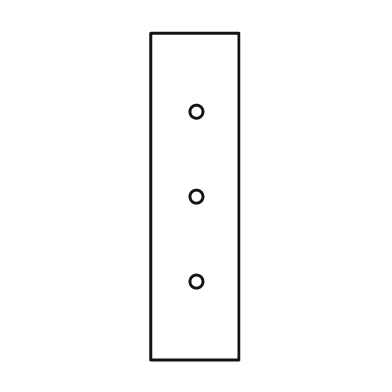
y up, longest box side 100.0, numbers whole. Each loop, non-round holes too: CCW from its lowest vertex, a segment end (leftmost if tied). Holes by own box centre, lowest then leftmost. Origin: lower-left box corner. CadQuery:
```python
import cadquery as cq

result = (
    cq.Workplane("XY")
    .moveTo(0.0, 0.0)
    .lineTo(27.0, 0.0)
    .lineTo(27.0, 100.0)
    .lineTo(0.0, 100.0)
    .close()
    .moveTo(14.0, 24.0)
    .circle(2.0)
    .moveTo(14.0, 50.0)
    .circle(2.0)
    .moveTo(14.0, 76.0)
    .circle(2.0)
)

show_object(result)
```